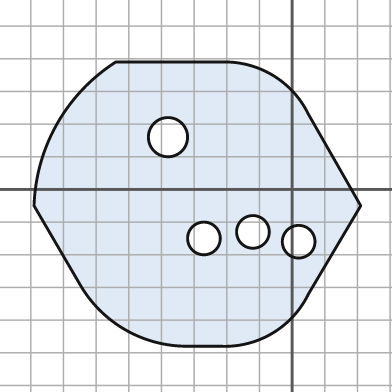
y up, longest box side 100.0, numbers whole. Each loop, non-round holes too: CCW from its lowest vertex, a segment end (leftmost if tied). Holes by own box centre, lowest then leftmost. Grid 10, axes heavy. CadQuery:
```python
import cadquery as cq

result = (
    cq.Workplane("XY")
    .moveTo(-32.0, -48.0)
    .lineTo(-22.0, -48.0)
    .threePointArc((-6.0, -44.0), (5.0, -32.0))
    .lineTo(21.0, -5.0)
    .lineTo(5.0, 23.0)
    .threePointArc((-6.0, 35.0), (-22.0, 39.0))
    .lineTo(-54.0, 39.0)
    .threePointArc((-72.0, 20.0), (-79.0, -5.0))
    .lineTo(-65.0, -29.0)
    .threePointArc((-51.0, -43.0), (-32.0, -48.0))
    .close()
    .moveTo(2.0, -16.0)
    .circle(5.0)
    .moveTo(-27.0, -15.0)
    .circle(5.0)
    .moveTo(-12.0, -13.0)
    .circle(5.0)
    .moveTo(-38.0, 16.0)
    .circle(6.0)
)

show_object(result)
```